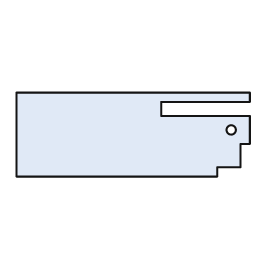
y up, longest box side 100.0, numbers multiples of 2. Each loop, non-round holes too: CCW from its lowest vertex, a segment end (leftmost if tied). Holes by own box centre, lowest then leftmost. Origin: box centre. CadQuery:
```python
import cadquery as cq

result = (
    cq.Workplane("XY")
    .moveTo(-50.0, -18.0)
    .lineTo(36.0, -18.0)
    .lineTo(36.0, -14.0)
    .lineTo(46.0, -14.0)
    .lineTo(46.0, -4.0)
    .lineTo(50.0, -4.0)
    .lineTo(50.0, 8.0)
    .lineTo(12.0, 8.0)
    .lineTo(12.0, 14.0)
    .lineTo(50.0, 14.0)
    .lineTo(50.0, 18.0)
    .lineTo(-50.0, 18.0)
    .close()
    .moveTo(42.0, 2.0)
    .circle(2.0)
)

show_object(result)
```